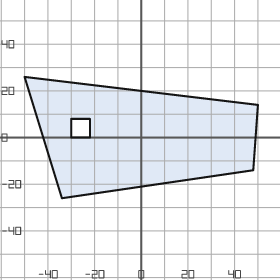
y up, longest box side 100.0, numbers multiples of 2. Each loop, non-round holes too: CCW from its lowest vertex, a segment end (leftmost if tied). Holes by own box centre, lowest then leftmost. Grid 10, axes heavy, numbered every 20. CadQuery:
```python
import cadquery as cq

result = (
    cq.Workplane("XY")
    .moveTo(-34.0, -26.0)
    .lineTo(48.0, -14.0)
    .lineTo(50.0, 14.0)
    .lineTo(-50.0, 26.0)
    .close()
    .moveTo(-30.0, 0.0)
    .lineTo(-22.0, 0.0)
    .lineTo(-22.0, 8.0)
    .lineTo(-30.0, 8.0)
    .close()
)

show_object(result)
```